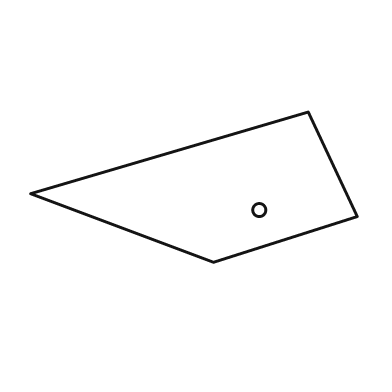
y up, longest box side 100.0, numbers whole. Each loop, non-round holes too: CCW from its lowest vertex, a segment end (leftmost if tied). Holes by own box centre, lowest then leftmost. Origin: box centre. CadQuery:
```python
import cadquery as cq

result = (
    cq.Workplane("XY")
    .moveTo(6.0, -23.0)
    .lineTo(50.0, -9.0)
    .lineTo(35.0, 23.0)
    .lineTo(-50.0, -2.0)
    .close()
    .moveTo(20.0, -7.0)
    .circle(2.0)
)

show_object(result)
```